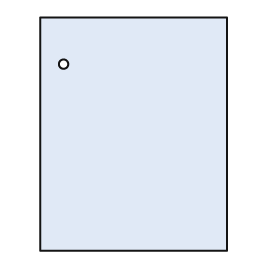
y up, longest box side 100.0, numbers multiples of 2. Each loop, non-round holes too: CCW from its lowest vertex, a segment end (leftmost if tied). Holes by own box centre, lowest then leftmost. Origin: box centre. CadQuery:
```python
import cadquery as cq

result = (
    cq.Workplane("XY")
    .moveTo(-40.0, -50.0)
    .lineTo(40.0, -50.0)
    .lineTo(40.0, 50.0)
    .lineTo(-40.0, 50.0)
    .close()
    .moveTo(-30.0, 30.0)
    .circle(2.0)
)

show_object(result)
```